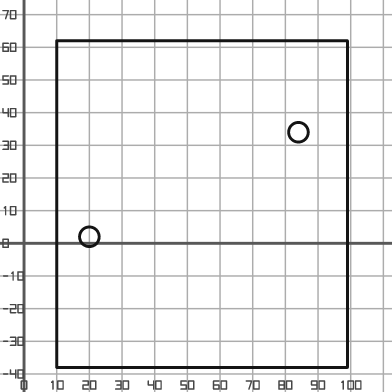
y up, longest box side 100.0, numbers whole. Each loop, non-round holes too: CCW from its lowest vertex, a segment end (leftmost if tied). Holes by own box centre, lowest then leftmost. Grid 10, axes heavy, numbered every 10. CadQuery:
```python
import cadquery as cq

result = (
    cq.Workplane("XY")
    .moveTo(10.0, -38.0)
    .lineTo(99.0, -38.0)
    .lineTo(99.0, 62.0)
    .lineTo(10.0, 62.0)
    .close()
    .moveTo(20.0, 2.0)
    .circle(3.0)
    .moveTo(84.0, 34.0)
    .circle(3.0)
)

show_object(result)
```